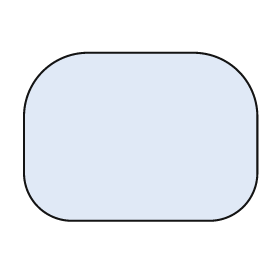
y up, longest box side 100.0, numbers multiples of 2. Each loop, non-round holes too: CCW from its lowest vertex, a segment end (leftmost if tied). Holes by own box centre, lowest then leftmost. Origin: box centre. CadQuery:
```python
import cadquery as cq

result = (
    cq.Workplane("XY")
    .moveTo(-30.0, -36.0)
    .lineTo(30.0, -36.0)
    .threePointArc((44.0, -30.0), (50.0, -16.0))
    .lineTo(50.0, 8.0)
    .threePointArc((42.0, 28.0), (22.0, 36.0))
    .lineTo(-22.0, 36.0)
    .threePointArc((-42.0, 28.0), (-50.0, 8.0))
    .lineTo(-50.0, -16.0)
    .threePointArc((-44.0, -30.0), (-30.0, -36.0))
    .close()
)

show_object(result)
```